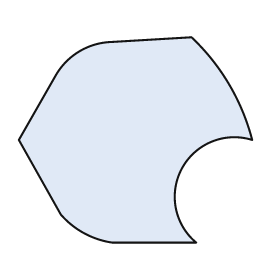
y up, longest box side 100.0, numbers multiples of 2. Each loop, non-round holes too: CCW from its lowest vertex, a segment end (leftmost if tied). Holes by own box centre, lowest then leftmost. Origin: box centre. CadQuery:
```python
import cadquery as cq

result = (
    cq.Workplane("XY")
    .moveTo(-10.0, -44.0)
    .lineTo(26.0, -44.0)
    .threePointArc((20.0, -12.0), (50.0, 0.0))
    .threePointArc((40.0, 24.0), (24.0, 44.0))
    .lineTo(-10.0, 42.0)
    .threePointArc((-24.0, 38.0), (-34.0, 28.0))
    .lineTo(-50.0, 0.0)
    .lineTo(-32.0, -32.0)
    .threePointArc((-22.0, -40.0), (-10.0, -44.0))
    .close()
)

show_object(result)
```